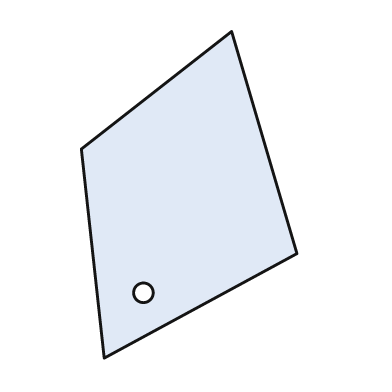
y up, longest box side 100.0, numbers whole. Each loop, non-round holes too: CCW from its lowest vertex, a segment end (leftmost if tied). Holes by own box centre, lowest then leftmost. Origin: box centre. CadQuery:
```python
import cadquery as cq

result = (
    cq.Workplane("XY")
    .moveTo(-26.0, -50.0)
    .lineTo(33.0, -18.0)
    .lineTo(13.0, 50.0)
    .lineTo(-33.0, 14.0)
    .close()
    .moveTo(-14.0, -30.0)
    .circle(3.0)
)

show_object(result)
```